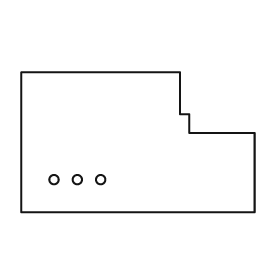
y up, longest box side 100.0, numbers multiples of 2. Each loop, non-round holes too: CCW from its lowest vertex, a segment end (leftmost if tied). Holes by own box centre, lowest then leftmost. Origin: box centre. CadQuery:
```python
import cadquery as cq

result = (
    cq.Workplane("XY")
    .moveTo(-50.0, -30.0)
    .lineTo(50.0, -30.0)
    .lineTo(50.0, 4.0)
    .lineTo(22.0, 4.0)
    .lineTo(22.0, 12.0)
    .lineTo(18.0, 12.0)
    .lineTo(18.0, 30.0)
    .lineTo(-50.0, 30.0)
    .close()
    .moveTo(-36.0, -16.0)
    .circle(2.0)
    .moveTo(-26.0, -16.0)
    .circle(2.0)
    .moveTo(-16.0, -16.0)
    .circle(2.0)
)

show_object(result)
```